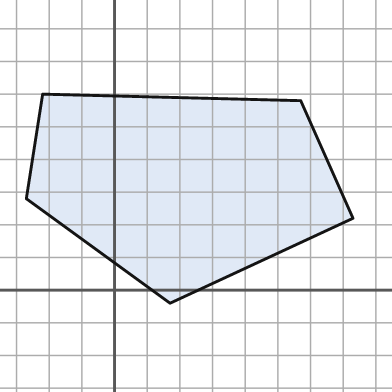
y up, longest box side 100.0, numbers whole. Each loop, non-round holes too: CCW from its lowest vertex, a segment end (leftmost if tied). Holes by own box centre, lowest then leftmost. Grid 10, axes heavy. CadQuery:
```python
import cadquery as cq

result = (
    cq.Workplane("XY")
    .moveTo(17.0, -4.0)
    .lineTo(73.0, 22.0)
    .lineTo(57.0, 58.0)
    .lineTo(-22.0, 60.0)
    .lineTo(-27.0, 28.0)
    .close()
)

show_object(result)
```